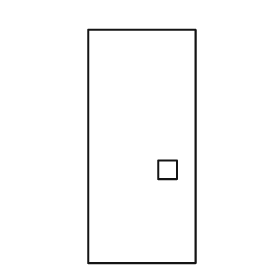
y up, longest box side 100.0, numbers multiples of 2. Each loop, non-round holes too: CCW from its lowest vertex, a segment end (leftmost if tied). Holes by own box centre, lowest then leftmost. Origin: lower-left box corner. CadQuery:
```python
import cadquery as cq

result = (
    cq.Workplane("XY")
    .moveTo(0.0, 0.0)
    .lineTo(46.0, 0.0)
    .lineTo(46.0, 100.0)
    .lineTo(0.0, 100.0)
    .close()
    .moveTo(30.0, 36.0)
    .lineTo(38.0, 36.0)
    .lineTo(38.0, 44.0)
    .lineTo(30.0, 44.0)
    .close()
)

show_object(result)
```